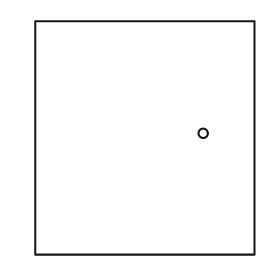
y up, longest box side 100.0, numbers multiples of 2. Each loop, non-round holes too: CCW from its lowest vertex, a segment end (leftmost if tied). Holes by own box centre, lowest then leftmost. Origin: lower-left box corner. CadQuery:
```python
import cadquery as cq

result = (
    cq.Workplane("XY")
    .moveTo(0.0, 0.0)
    .lineTo(94.0, 0.0)
    .lineTo(94.0, 100.0)
    .lineTo(0.0, 100.0)
    .close()
    .moveTo(72.0, 52.0)
    .circle(2.0)
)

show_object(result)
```